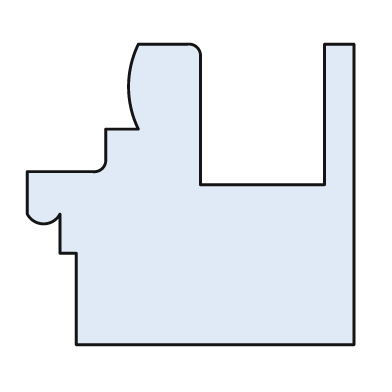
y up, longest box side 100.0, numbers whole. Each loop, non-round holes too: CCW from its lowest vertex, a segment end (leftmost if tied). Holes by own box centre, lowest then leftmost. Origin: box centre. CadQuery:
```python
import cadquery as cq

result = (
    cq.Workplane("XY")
    .moveTo(-35.0, -46.0)
    .lineTo(50.0, -46.0)
    .lineTo(50.0, 46.0)
    .lineTo(41.0, 46.0)
    .lineTo(41.0, 3.0)
    .lineTo(3.0, 3.0)
    .lineTo(3.0, 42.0)
    .threePointArc((2.0, 45.0), (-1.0, 46.0))
    .lineTo(-16.0, 46.0)
    .threePointArc((-19.0, 33.0), (-16.0, 20.0))
    .lineTo(-26.0, 20.0)
    .lineTo(-26.0, 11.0)
    .threePointArc((-27.0, 8.0), (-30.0, 7.0))
    .lineTo(-50.0, 7.0)
    .lineTo(-50.0, -6.0)
    .threePointArc((-45.0, -9.0), (-40.0, -6.0))
    .lineTo(-40.0, -18.0)
    .lineTo(-35.0, -18.0)
    .close()
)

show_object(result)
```